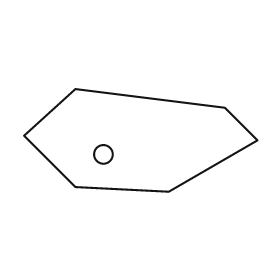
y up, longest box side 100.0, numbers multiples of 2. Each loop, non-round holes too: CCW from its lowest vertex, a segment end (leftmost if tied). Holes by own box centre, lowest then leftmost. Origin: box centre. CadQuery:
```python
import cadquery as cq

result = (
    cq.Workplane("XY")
    .moveTo(12.0, -22.0)
    .lineTo(50.0, 0.0)
    .lineTo(36.0, 14.0)
    .lineTo(-28.0, 22.0)
    .lineTo(-50.0, 2.0)
    .lineTo(-28.0, -20.0)
    .close()
    .moveTo(-16.0, -6.0)
    .circle(4.0)
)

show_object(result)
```